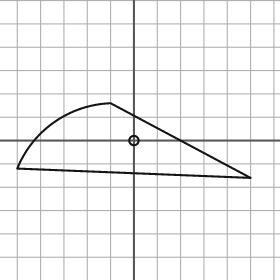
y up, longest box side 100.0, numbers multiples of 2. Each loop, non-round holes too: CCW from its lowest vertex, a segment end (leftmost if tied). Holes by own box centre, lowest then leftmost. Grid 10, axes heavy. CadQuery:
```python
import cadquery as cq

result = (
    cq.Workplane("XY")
    .moveTo(50.0, -16.0)
    .lineTo(-10.0, 16.0)
    .threePointArc((-34.0, 8.0), (-50.0, -12.0))
    .close()
    .moveTo(0.0, 0.0)
    .circle(2.0)
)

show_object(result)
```